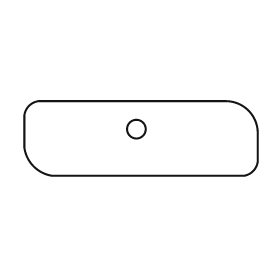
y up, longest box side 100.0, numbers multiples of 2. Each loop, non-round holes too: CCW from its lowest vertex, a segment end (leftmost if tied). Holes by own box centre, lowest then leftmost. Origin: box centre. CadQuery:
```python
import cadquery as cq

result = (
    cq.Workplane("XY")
    .moveTo(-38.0, -16.0)
    .lineTo(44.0, -16.0)
    .threePointArc((48.0, -14.0), (50.0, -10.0))
    .lineTo(50.0, 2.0)
    .threePointArc((46.0, 12.0), (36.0, 16.0))
    .lineTo(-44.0, 16.0)
    .threePointArc((-48.0, 14.0), (-50.0, 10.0))
    .lineTo(-50.0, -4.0)
    .threePointArc((-46.0, -12.0), (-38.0, -16.0))
    .close()
    .moveTo(-2.0, 4.0)
    .circle(4.0)
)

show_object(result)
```